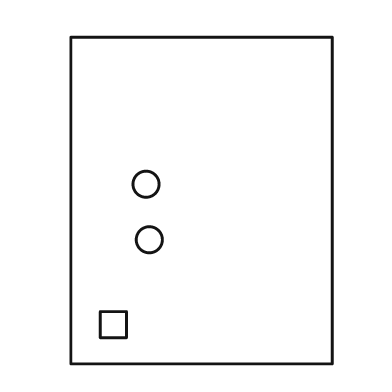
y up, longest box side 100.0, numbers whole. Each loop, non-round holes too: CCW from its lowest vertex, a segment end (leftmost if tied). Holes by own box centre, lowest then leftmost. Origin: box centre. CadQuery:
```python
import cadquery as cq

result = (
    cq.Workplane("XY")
    .moveTo(-40.0, -50.0)
    .lineTo(40.0, -50.0)
    .lineTo(40.0, 50.0)
    .lineTo(-40.0, 50.0)
    .close()
    .moveTo(-31.0, -42.0)
    .lineTo(-23.0, -42.0)
    .lineTo(-23.0, -34.0)
    .lineTo(-31.0, -34.0)
    .close()
    .moveTo(-16.0, -12.0)
    .circle(4.0)
    .moveTo(-17.0, 5.0)
    .circle(4.0)
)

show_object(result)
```